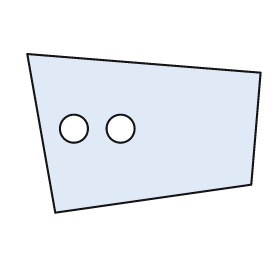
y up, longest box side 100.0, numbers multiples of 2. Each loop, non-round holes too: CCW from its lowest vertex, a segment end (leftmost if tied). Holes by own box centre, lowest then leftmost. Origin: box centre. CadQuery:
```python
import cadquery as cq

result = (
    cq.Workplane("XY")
    .moveTo(-38.0, -34.0)
    .lineTo(46.0, -22.0)
    .lineTo(50.0, 26.0)
    .lineTo(-50.0, 34.0)
    .close()
    .moveTo(-30.0, 2.0)
    .circle(6.0)
    .moveTo(-10.0, 2.0)
    .circle(6.0)
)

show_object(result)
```